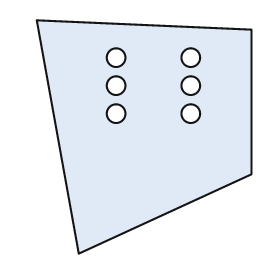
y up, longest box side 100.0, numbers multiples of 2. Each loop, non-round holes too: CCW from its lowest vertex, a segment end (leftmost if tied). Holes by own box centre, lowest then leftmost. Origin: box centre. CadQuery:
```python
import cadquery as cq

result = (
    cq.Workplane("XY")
    .moveTo(-28.0, -50.0)
    .lineTo(46.0, -16.0)
    .lineTo(46.0, 46.0)
    .lineTo(-46.0, 50.0)
    .close()
    .moveTo(-12.0, 10.0)
    .circle(4.0)
    .moveTo(20.0, 10.0)
    .circle(4.0)
    .moveTo(-12.0, 22.0)
    .circle(4.0)
    .moveTo(20.0, 22.0)
    .circle(4.0)
    .moveTo(-12.0, 34.0)
    .circle(4.0)
    .moveTo(20.0, 34.0)
    .circle(4.0)
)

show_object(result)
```